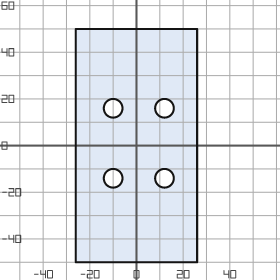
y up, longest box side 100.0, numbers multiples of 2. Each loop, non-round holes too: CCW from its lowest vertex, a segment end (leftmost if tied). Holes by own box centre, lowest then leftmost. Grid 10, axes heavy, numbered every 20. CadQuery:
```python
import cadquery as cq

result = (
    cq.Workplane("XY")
    .moveTo(-26.0, -50.0)
    .lineTo(26.0, -50.0)
    .lineTo(26.0, 50.0)
    .lineTo(-26.0, 50.0)
    .close()
    .moveTo(-10.0, -14.0)
    .circle(4.0)
    .moveTo(12.0, -14.0)
    .circle(4.0)
    .moveTo(-10.0, 16.0)
    .circle(4.0)
    .moveTo(12.0, 16.0)
    .circle(4.0)
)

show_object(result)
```